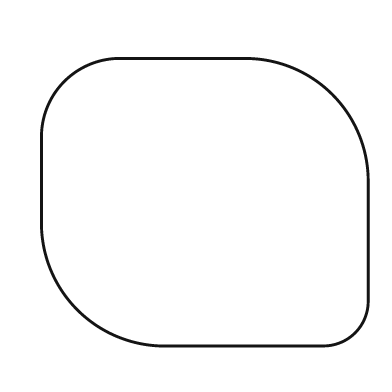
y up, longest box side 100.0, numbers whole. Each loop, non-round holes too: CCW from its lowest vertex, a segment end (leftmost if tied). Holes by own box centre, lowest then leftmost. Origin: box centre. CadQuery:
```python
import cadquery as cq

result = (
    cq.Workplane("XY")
    .moveTo(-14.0, -44.0)
    .lineTo(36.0, -44.0)
    .threePointArc((46.0, -40.0), (50.0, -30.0))
    .lineTo(50.0, 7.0)
    .threePointArc((39.0, 33.0), (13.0, 44.0))
    .lineTo(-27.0, 44.0)
    .threePointArc((-43.0, 37.0), (-50.0, 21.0))
    .lineTo(-50.0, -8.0)
    .threePointArc((-39.0, -33.0), (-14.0, -44.0))
    .close()
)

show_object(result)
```